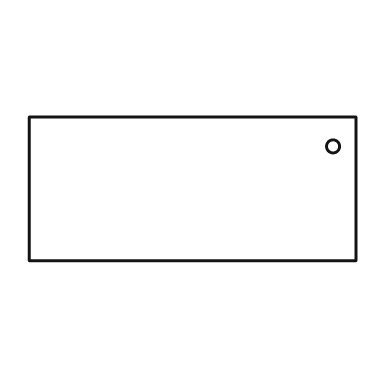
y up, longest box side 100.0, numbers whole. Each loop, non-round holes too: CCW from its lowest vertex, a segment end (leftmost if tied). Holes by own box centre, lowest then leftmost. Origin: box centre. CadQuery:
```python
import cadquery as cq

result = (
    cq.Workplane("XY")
    .moveTo(-50.0, -22.0)
    .lineTo(50.0, -22.0)
    .lineTo(50.0, 22.0)
    .lineTo(-50.0, 22.0)
    .close()
    .moveTo(43.0, 13.0)
    .circle(2.0)
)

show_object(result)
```